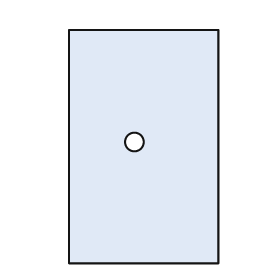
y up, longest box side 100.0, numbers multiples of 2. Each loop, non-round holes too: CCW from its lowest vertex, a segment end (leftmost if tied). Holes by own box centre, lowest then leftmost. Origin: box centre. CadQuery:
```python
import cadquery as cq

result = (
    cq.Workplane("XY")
    .moveTo(-32.0, -50.0)
    .lineTo(32.0, -50.0)
    .lineTo(32.0, 50.0)
    .lineTo(-32.0, 50.0)
    .close()
    .moveTo(-4.0, 2.0)
    .circle(4.0)
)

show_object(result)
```